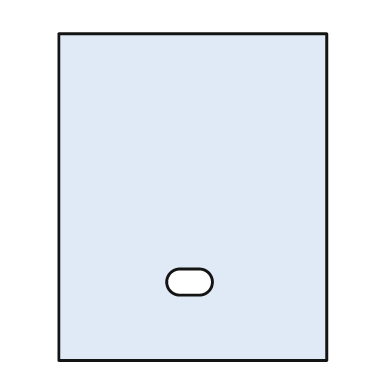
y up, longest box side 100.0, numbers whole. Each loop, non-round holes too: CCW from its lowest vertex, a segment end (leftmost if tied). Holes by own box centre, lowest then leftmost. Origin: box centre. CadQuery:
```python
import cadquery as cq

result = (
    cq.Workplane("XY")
    .moveTo(-41.0, -50.0)
    .lineTo(41.0, -50.0)
    .lineTo(41.0, 50.0)
    .lineTo(-41.0, 50.0)
    .close()
    .moveTo(-4.0, -30.0)
    .lineTo(2.0, -30.0)
    .threePointArc((6.0, -26.0), (2.0, -22.0))
    .lineTo(-4.0, -22.0)
    .threePointArc((-8.0, -26.0), (-4.0, -30.0))
    .close()
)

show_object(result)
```